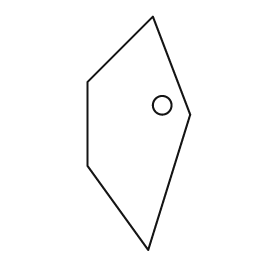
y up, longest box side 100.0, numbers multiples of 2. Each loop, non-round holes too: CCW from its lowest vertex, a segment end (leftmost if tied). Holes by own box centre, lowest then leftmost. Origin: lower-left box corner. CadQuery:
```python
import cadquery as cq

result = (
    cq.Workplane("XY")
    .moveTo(26.0, 0.0)
    .lineTo(44.0, 58.0)
    .lineTo(28.0, 100.0)
    .lineTo(0.0, 72.0)
    .lineTo(0.0, 36.0)
    .close()
    .moveTo(32.0, 62.0)
    .circle(4.0)
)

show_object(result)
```